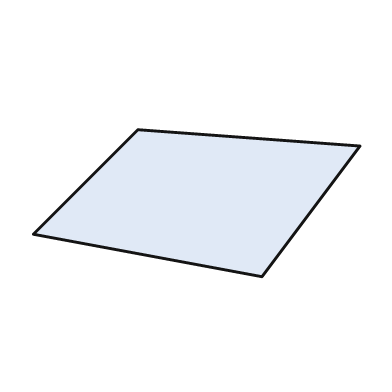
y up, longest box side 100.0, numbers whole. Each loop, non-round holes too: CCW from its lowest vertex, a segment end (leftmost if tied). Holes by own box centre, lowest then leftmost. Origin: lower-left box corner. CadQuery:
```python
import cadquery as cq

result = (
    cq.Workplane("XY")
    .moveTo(70.0, 0.0)
    .lineTo(100.0, 40.0)
    .lineTo(32.0, 45.0)
    .lineTo(0.0, 13.0)
    .close()
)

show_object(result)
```